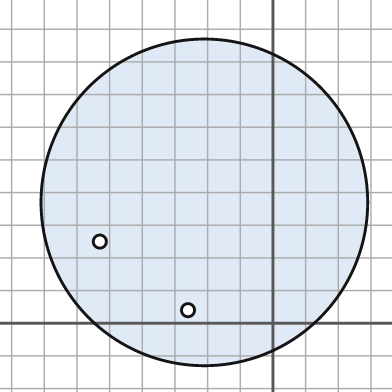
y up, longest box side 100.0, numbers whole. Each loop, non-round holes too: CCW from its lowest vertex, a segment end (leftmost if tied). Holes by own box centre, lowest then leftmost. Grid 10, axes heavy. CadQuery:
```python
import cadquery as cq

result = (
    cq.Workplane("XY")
    .moveTo(-21.0, 37.0)
    .circle(50.0)
    .moveTo(-26.0, 4.0)
    .circle(2.0)
    .moveTo(-53.0, 25.0)
    .circle(2.0)
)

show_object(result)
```